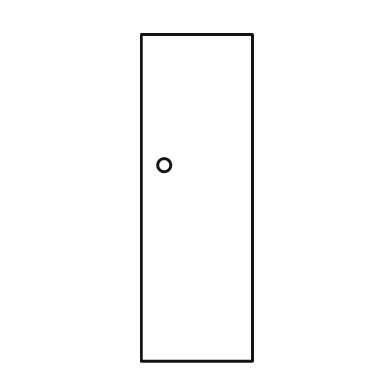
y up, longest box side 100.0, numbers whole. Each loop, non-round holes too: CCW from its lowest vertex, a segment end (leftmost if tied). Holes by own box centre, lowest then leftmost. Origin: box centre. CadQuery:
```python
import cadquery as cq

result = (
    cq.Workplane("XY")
    .moveTo(-17.0, -50.0)
    .lineTo(17.0, -50.0)
    .lineTo(17.0, 50.0)
    .lineTo(-17.0, 50.0)
    .close()
    .moveTo(-10.0, 10.0)
    .circle(2.0)
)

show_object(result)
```